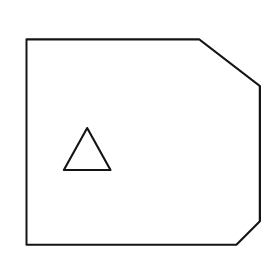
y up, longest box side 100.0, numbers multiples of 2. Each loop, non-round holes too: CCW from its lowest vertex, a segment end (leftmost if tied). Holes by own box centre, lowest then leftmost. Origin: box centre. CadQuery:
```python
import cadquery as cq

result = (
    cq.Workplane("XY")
    .moveTo(-50.0, -44.0)
    .lineTo(40.0, -44.0)
    .lineTo(50.0, -34.0)
    .lineTo(50.0, 24.0)
    .lineTo(24.0, 44.0)
    .lineTo(-50.0, 44.0)
    .close()
    .moveTo(-34.0, -12.0)
    .lineTo(-14.0, -12.0)
    .lineTo(-24.0, 6.0)
    .close()
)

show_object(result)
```